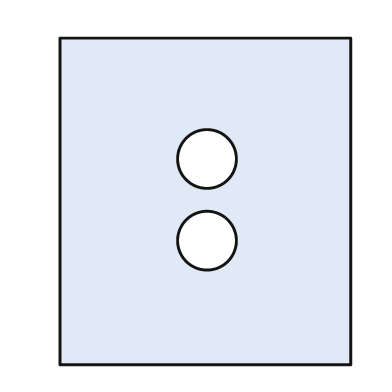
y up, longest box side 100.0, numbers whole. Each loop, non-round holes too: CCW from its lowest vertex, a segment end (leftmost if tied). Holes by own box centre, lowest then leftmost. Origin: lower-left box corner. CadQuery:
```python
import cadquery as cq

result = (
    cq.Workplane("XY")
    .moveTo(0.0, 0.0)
    .lineTo(89.0, 0.0)
    .lineTo(89.0, 100.0)
    .lineTo(0.0, 100.0)
    .close()
    .moveTo(45.0, 38.0)
    .circle(9.0)
    .moveTo(45.0, 63.0)
    .circle(9.0)
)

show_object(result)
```